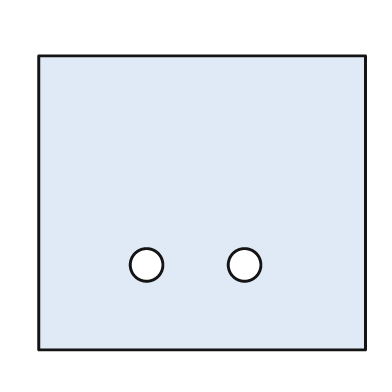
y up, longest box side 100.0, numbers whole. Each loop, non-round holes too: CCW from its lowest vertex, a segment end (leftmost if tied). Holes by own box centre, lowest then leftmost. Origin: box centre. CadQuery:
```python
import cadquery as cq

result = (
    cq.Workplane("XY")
    .moveTo(-50.0, -45.0)
    .lineTo(50.0, -45.0)
    .lineTo(50.0, 45.0)
    .lineTo(-50.0, 45.0)
    .close()
    .moveTo(-17.0, -19.0)
    .circle(5.0)
    .moveTo(13.0, -19.0)
    .circle(5.0)
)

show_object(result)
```